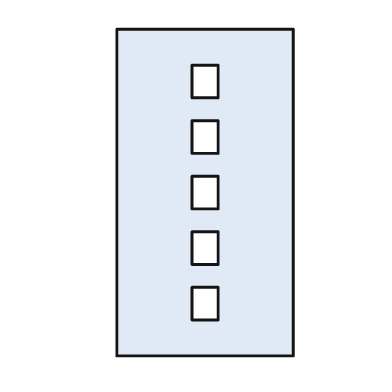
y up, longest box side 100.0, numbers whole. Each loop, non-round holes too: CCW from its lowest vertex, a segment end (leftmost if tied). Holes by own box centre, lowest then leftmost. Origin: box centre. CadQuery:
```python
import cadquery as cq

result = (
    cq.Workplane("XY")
    .moveTo(-27.0, -50.0)
    .lineTo(27.0, -50.0)
    .lineTo(27.0, 50.0)
    .lineTo(-27.0, 50.0)
    .close()
    .moveTo(-4.0, -39.0)
    .lineTo(4.0, -39.0)
    .lineTo(4.0, -29.0)
    .lineTo(-4.0, -29.0)
    .close()
    .moveTo(-4.0, -22.0)
    .lineTo(4.0, -22.0)
    .lineTo(4.0, -12.0)
    .lineTo(-4.0, -12.0)
    .close()
    .moveTo(-4.0, -5.0)
    .lineTo(4.0, -5.0)
    .lineTo(4.0, 5.0)
    .lineTo(-4.0, 5.0)
    .close()
    .moveTo(-4.0, 12.0)
    .lineTo(4.0, 12.0)
    .lineTo(4.0, 22.0)
    .lineTo(-4.0, 22.0)
    .close()
    .moveTo(-4.0, 29.0)
    .lineTo(4.0, 29.0)
    .lineTo(4.0, 39.0)
    .lineTo(-4.0, 39.0)
    .close()
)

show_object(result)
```